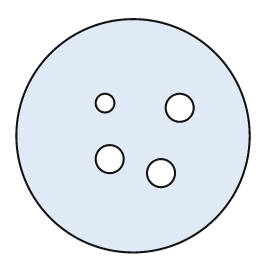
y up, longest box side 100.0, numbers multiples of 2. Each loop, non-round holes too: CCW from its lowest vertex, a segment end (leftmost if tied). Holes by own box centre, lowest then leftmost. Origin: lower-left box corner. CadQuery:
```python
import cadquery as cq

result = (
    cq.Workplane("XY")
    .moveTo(50.0, 50.0)
    .circle(50.0)
    .moveTo(62.0, 34.0)
    .circle(6.0)
    .moveTo(40.0, 40.0)
    .circle(6.0)
    .moveTo(70.0, 62.0)
    .circle(6.0)
    .moveTo(38.0, 64.0)
    .circle(4.0)
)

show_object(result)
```